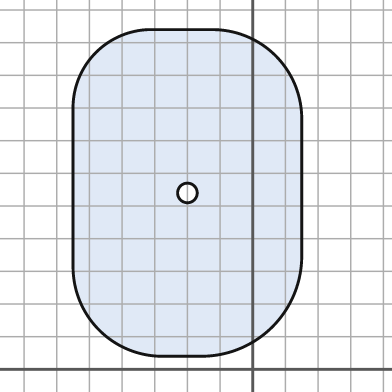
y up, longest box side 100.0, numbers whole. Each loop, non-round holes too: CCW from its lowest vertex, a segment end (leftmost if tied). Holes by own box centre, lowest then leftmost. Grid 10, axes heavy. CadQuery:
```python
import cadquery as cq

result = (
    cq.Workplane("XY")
    .moveTo(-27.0, 4.0)
    .lineTo(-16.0, 4.0)
    .threePointArc((6.0, 13.0), (15.0, 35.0))
    .lineTo(15.0, 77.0)
    .threePointArc((7.0, 96.0), (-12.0, 104.0))
    .lineTo(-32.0, 104.0)
    .threePointArc((-48.0, 97.0), (-55.0, 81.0))
    .lineTo(-55.0, 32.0)
    .threePointArc((-47.0, 12.0), (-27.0, 4.0))
    .close()
    .moveTo(-20.0, 54.0)
    .circle(3.0)
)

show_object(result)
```